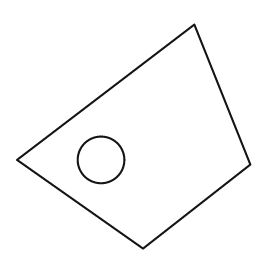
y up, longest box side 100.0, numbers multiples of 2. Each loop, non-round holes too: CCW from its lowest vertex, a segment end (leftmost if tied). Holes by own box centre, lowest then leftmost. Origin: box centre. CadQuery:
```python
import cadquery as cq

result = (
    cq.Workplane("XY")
    .moveTo(4.0, -48.0)
    .lineTo(50.0, -12.0)
    .lineTo(26.0, 48.0)
    .lineTo(-50.0, -10.0)
    .close()
    .moveTo(-14.0, -10.0)
    .circle(10.0)
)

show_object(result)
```